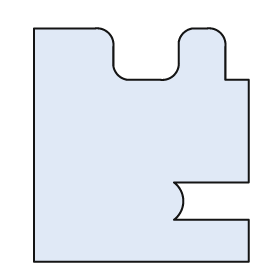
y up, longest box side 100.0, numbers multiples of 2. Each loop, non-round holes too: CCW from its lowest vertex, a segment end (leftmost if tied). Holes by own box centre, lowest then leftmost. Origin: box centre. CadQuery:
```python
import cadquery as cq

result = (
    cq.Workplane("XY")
    .moveTo(-46.0, -50.0)
    .lineTo(46.0, -50.0)
    .lineTo(46.0, -32.0)
    .lineTo(14.0, -32.0)
    .threePointArc((18.0, -24.0), (14.0, -16.0))
    .lineTo(46.0, -16.0)
    .lineTo(46.0, 28.0)
    .lineTo(36.0, 28.0)
    .lineTo(36.0, 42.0)
    .threePointArc((34.0, 48.0), (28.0, 50.0))
    .lineTo(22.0, 50.0)
    .threePointArc((18.0, 48.0), (16.0, 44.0))
    .lineTo(16.0, 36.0)
    .threePointArc((14.0, 30.0), (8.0, 28.0))
    .lineTo(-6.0, 28.0)
    .threePointArc((-10.0, 30.0), (-12.0, 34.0))
    .lineTo(-12.0, 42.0)
    .threePointArc((-14.0, 48.0), (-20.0, 50.0))
    .lineTo(-46.0, 50.0)
    .close()
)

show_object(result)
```